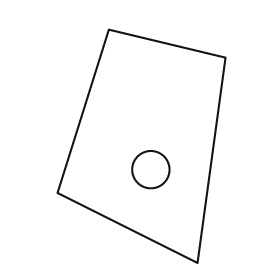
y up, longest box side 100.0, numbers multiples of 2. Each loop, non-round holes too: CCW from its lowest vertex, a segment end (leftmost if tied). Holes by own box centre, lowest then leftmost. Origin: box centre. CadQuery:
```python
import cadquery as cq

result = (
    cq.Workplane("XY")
    .moveTo(24.0, -50.0)
    .lineTo(36.0, 38.0)
    .lineTo(-14.0, 50.0)
    .lineTo(-36.0, -20.0)
    .close()
    .moveTo(4.0, -10.0)
    .circle(8.0)
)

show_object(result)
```